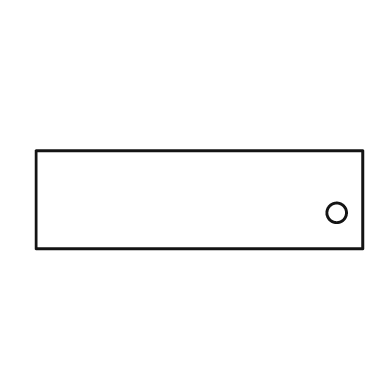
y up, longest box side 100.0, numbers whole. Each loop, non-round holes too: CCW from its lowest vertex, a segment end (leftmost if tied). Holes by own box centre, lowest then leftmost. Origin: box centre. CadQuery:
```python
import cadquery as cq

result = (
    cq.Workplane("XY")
    .moveTo(-50.0, -15.0)
    .lineTo(50.0, -15.0)
    .lineTo(50.0, 15.0)
    .lineTo(-50.0, 15.0)
    .close()
    .moveTo(42.0, -4.0)
    .circle(3.0)
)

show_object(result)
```